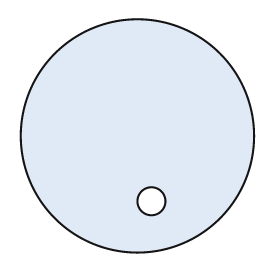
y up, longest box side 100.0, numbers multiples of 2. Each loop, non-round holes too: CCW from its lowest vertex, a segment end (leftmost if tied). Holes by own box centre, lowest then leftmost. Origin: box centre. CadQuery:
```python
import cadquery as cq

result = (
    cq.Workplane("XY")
    .moveTo(0.0, 0.0)
    .circle(50.0)
    .moveTo(6.0, -28.0)
    .circle(6.0)
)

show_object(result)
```